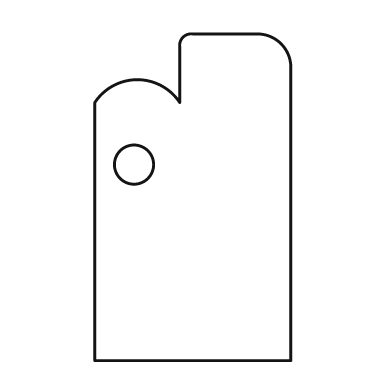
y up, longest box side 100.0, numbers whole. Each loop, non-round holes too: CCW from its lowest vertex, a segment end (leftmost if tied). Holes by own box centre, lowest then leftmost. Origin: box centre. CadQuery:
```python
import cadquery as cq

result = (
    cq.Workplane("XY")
    .moveTo(-30.0, -50.0)
    .lineTo(30.0, -50.0)
    .lineTo(30.0, 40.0)
    .threePointArc((27.0, 47.0), (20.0, 50.0))
    .lineTo(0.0, 50.0)
    .threePointArc((-3.0, 49.0), (-4.0, 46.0))
    .lineTo(-4.0, 29.0)
    .threePointArc((-17.0, 36.0), (-30.0, 29.0))
    .close()
    .moveTo(-18.0, 10.0)
    .circle(6.0)
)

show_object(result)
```